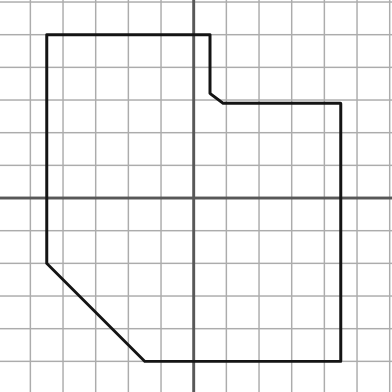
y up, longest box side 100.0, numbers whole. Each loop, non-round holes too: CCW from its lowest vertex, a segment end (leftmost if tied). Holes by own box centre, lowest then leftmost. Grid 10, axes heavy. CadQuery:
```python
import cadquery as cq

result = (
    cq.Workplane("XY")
    .moveTo(-15.0, -50.0)
    .lineTo(45.0, -50.0)
    .lineTo(45.0, 29.0)
    .lineTo(9.0, 29.0)
    .lineTo(5.0, 32.0)
    .lineTo(5.0, 50.0)
    .lineTo(-45.0, 50.0)
    .lineTo(-45.0, -20.0)
    .close()
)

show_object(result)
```